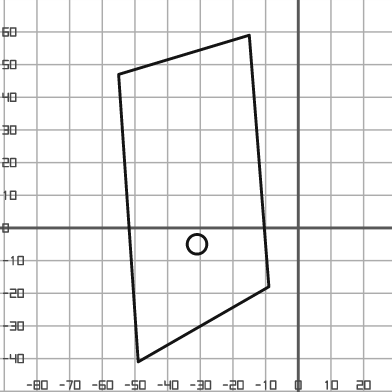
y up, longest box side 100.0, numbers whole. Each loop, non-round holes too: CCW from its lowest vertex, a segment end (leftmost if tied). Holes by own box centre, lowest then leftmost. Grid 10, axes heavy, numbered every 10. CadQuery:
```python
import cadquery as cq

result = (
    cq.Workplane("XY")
    .moveTo(-49.0, -41.0)
    .lineTo(-9.0, -18.0)
    .lineTo(-15.0, 59.0)
    .lineTo(-55.0, 47.0)
    .close()
    .moveTo(-31.0, -5.0)
    .circle(3.0)
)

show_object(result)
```